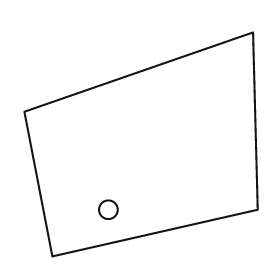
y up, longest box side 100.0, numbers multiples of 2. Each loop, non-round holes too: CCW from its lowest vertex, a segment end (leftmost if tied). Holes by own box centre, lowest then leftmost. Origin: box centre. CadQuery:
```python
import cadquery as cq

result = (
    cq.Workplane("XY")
    .moveTo(-38.0, -48.0)
    .lineTo(50.0, -28.0)
    .lineTo(48.0, 48.0)
    .lineTo(-50.0, 14.0)
    .close()
    .moveTo(-14.0, -28.0)
    .circle(4.0)
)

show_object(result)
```